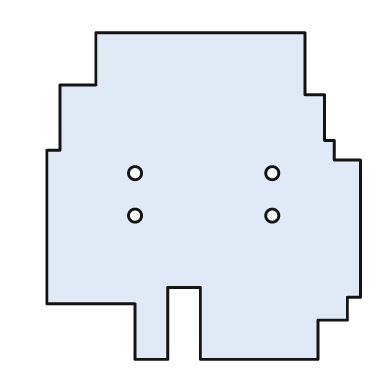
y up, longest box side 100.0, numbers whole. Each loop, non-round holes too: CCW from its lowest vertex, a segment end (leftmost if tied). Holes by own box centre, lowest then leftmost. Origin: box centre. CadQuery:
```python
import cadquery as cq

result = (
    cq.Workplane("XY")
    .moveTo(-21.0, -50.0)
    .lineTo(-11.0, -50.0)
    .lineTo(-11.0, -28.0)
    .lineTo(-1.0, -28.0)
    .lineTo(-1.0, -50.0)
    .lineTo(35.0, -50.0)
    .lineTo(35.0, -38.0)
    .lineTo(44.0, -38.0)
    .lineTo(44.0, -31.0)
    .lineTo(48.0, -31.0)
    .lineTo(48.0, 11.0)
    .lineTo(40.0, 11.0)
    .lineTo(40.0, 17.0)
    .lineTo(37.0, 17.0)
    .lineTo(37.0, 31.0)
    .lineTo(31.0, 31.0)
    .lineTo(31.0, 50.0)
    .lineTo(-33.0, 50.0)
    .lineTo(-33.0, 34.0)
    .lineTo(-44.0, 34.0)
    .lineTo(-44.0, 14.0)
    .lineTo(-48.0, 14.0)
    .lineTo(-48.0, -33.0)
    .lineTo(-21.0, -33.0)
    .close()
    .moveTo(-21.0, -6.0)
    .circle(2.0)
    .moveTo(21.0, -6.0)
    .circle(2.0)
    .moveTo(-21.0, 7.0)
    .circle(2.0)
    .moveTo(21.0, 7.0)
    .circle(2.0)
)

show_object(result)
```